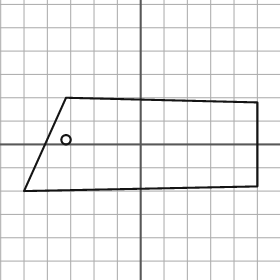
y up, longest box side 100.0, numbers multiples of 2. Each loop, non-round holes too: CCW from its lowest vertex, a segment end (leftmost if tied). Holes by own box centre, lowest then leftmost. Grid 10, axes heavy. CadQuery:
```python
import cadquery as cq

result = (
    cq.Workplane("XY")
    .moveTo(-50.0, -20.0)
    .lineTo(50.0, -18.0)
    .lineTo(50.0, 18.0)
    .lineTo(-32.0, 20.0)
    .close()
    .moveTo(-32.0, 2.0)
    .circle(2.0)
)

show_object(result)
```